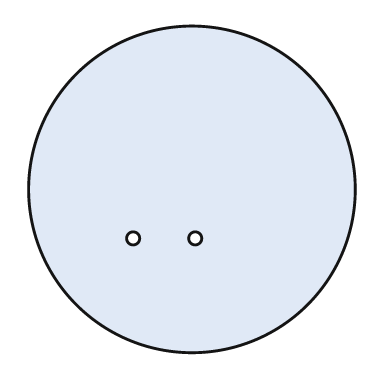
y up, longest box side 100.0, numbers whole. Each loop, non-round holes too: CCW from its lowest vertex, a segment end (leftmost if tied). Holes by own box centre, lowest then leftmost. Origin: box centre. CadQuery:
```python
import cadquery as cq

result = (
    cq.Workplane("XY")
    .moveTo(0.0, 0.0)
    .circle(50.0)
    .moveTo(-18.0, -15.0)
    .circle(2.0)
    .moveTo(1.0, -15.0)
    .circle(2.0)
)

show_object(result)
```